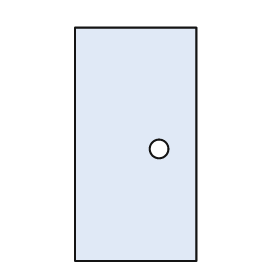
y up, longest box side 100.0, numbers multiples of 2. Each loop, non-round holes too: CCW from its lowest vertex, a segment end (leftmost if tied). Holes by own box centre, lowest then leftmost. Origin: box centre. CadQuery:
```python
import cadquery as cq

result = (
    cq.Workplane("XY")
    .moveTo(-26.0, -50.0)
    .lineTo(26.0, -50.0)
    .lineTo(26.0, 50.0)
    .lineTo(-26.0, 50.0)
    .close()
    .moveTo(10.0, -2.0)
    .circle(4.0)
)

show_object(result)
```